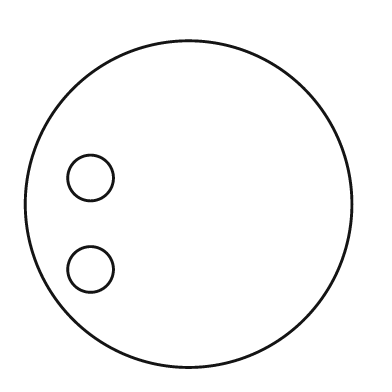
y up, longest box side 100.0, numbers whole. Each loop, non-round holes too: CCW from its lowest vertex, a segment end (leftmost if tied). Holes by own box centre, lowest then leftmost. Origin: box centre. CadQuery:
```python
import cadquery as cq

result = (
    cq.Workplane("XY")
    .moveTo(0.0, 0.0)
    .circle(50.0)
    .moveTo(-30.0, -20.0)
    .circle(7.0)
    .moveTo(-30.0, 8.0)
    .circle(7.0)
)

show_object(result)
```